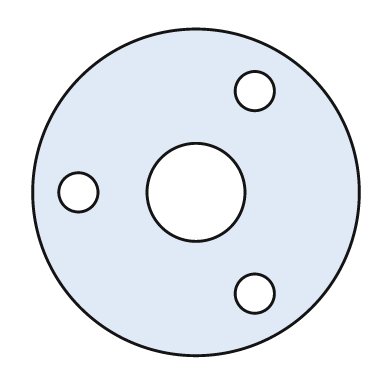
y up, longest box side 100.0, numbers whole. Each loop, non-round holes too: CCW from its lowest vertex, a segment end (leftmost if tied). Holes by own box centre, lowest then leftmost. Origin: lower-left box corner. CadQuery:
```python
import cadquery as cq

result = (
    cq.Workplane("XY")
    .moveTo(50.0, 50.0)
    .circle(50.0)
    .moveTo(68.0, 19.0)
    .circle(6.0)
    .moveTo(14.0, 50.0)
    .circle(6.0)
    .moveTo(50.0, 50.0)
    .circle(15.0)
    .moveTo(68.0, 81.0)
    .circle(6.0)
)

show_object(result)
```